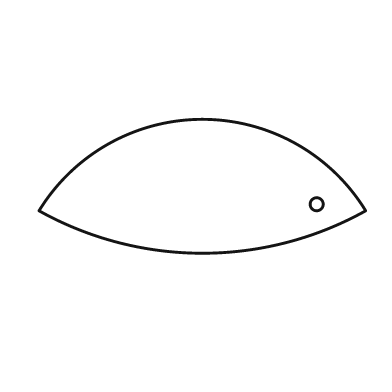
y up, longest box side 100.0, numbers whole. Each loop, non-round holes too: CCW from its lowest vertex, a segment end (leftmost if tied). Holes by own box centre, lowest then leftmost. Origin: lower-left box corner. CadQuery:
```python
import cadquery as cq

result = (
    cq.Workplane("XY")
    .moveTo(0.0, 13.0)
    .threePointArc((50.0, 0.0), (100.0, 13.0))
    .threePointArc((50.0, 41.0), (0.0, 13.0))
    .close()
    .moveTo(85.0, 15.0)
    .circle(2.0)
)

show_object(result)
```